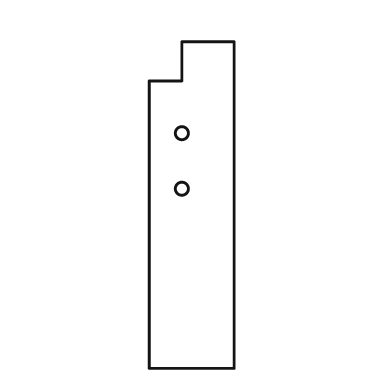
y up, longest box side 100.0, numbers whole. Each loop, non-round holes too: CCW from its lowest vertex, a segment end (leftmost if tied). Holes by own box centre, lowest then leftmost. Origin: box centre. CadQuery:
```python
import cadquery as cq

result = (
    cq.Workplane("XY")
    .moveTo(-13.0, -50.0)
    .lineTo(13.0, -50.0)
    .lineTo(13.0, 50.0)
    .lineTo(-3.0, 50.0)
    .lineTo(-3.0, 38.0)
    .lineTo(-13.0, 38.0)
    .close()
    .moveTo(-3.0, 5.0)
    .circle(2.0)
    .moveTo(-3.0, 22.0)
    .circle(2.0)
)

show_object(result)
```